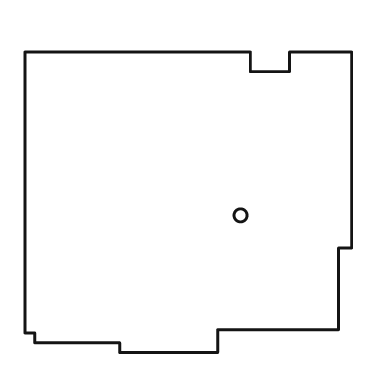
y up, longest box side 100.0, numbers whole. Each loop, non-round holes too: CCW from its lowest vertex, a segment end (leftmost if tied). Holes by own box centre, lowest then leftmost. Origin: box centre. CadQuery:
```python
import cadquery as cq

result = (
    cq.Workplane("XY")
    .moveTo(-21.0, -46.0)
    .lineTo(9.0, -46.0)
    .lineTo(9.0, -39.0)
    .lineTo(46.0, -39.0)
    .lineTo(46.0, -14.0)
    .lineTo(50.0, -14.0)
    .lineTo(50.0, 46.0)
    .lineTo(31.0, 46.0)
    .lineTo(31.0, 40.0)
    .lineTo(19.0, 40.0)
    .lineTo(19.0, 46.0)
    .lineTo(-50.0, 46.0)
    .lineTo(-50.0, -40.0)
    .lineTo(-47.0, -40.0)
    .lineTo(-47.0, -43.0)
    .lineTo(-21.0, -43.0)
    .close()
    .moveTo(16.0, -4.0)
    .circle(2.0)
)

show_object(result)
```